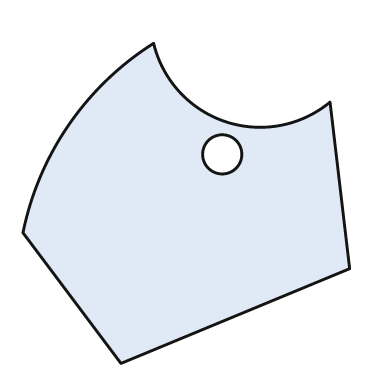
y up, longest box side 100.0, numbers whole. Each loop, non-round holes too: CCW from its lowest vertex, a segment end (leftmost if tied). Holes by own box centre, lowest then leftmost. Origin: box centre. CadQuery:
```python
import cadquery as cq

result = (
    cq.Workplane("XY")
    .moveTo(-20.0, -49.0)
    .lineTo(50.0, -20.0)
    .lineTo(44.0, 31.0)
    .threePointArc((12.0, 25.0), (-10.0, 49.0))
    .threePointArc((-36.0, 24.0), (-50.0, -9.0))
    .close()
    .moveTo(11.0, 15.0)
    .circle(6.0)
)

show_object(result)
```